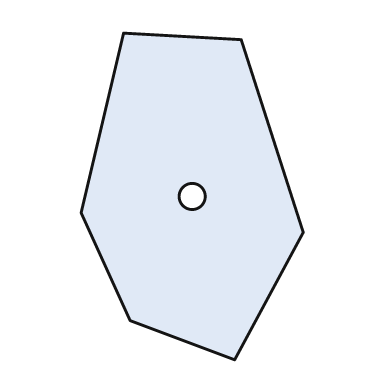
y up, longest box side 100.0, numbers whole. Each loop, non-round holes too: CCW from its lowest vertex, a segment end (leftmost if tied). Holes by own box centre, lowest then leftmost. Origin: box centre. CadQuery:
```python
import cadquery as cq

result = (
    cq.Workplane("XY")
    .moveTo(13.0, -50.0)
    .lineTo(34.0, -11.0)
    .lineTo(15.0, 48.0)
    .lineTo(-21.0, 50.0)
    .lineTo(-34.0, -5.0)
    .lineTo(-19.0, -38.0)
    .close()
    .moveTo(0.0, 0.0)
    .circle(4.0)
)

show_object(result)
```